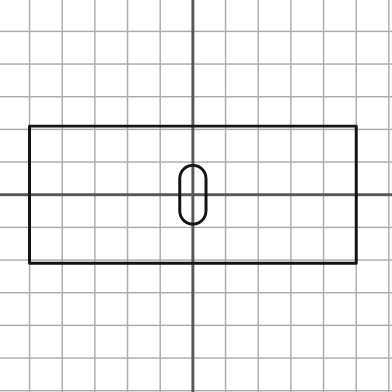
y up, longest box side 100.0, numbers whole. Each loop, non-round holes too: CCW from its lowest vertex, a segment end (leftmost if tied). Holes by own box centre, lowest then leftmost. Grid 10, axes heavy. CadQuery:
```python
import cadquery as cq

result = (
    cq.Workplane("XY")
    .moveTo(-50.0, -21.0)
    .lineTo(50.0, -21.0)
    .lineTo(50.0, 21.0)
    .lineTo(-50.0, 21.0)
    .close()
    .moveTo(-4.0, -5.0)
    .threePointArc((0.0, -9.0), (4.0, -5.0))
    .lineTo(4.0, 5.0)
    .threePointArc((0.0, 9.0), (-4.0, 5.0))
    .close()
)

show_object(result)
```